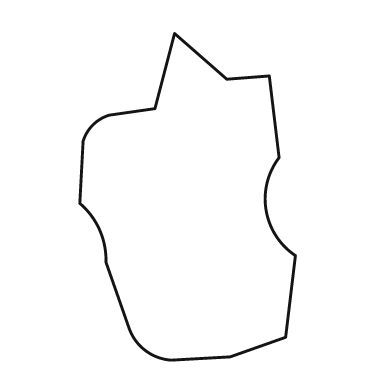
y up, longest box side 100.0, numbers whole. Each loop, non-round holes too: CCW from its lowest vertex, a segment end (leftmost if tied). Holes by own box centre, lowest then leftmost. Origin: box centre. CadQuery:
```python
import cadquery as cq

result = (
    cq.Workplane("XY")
    .moveTo(-5.0, -50.0)
    .lineTo(13.0, -49.0)
    .lineTo(30.0, -43.0)
    .lineTo(33.0, -18.0)
    .threePointArc((24.0, -4.0), (28.0, 12.0))
    .lineTo(25.0, 37.0)
    .lineTo(12.0, 36.0)
    .lineTo(-4.0, 50.0)
    .lineTo(-10.0, 27.0)
    .lineTo(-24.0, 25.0)
    .threePointArc((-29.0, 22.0), (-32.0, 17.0))
    .lineTo(-33.0, -2.0)
    .threePointArc((-27.0, -10.0), (-25.0, -20.0))
    .lineTo(-18.0, -40.0)
    .threePointArc((-13.0, -47.0), (-5.0, -50.0))
    .close()
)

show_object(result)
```